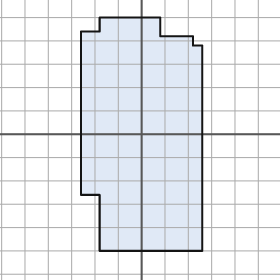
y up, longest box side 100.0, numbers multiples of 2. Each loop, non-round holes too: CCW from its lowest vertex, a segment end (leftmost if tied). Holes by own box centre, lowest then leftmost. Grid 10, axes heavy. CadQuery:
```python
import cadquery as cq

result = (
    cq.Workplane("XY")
    .moveTo(-18.0, -50.0)
    .lineTo(26.0, -50.0)
    .lineTo(26.0, 38.0)
    .lineTo(22.0, 38.0)
    .lineTo(22.0, 42.0)
    .lineTo(8.0, 42.0)
    .lineTo(8.0, 50.0)
    .lineTo(-18.0, 50.0)
    .lineTo(-18.0, 44.0)
    .lineTo(-26.0, 44.0)
    .lineTo(-26.0, -26.0)
    .lineTo(-18.0, -26.0)
    .close()
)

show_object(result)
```